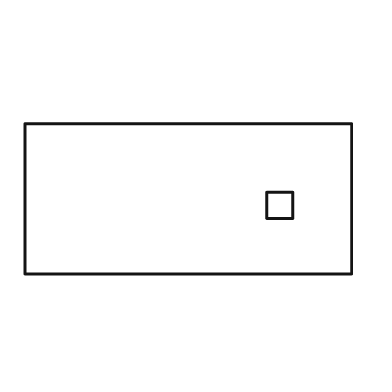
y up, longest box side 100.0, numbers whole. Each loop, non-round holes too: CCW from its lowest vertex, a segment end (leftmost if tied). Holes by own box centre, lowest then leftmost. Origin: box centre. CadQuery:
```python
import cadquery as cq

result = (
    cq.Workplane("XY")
    .moveTo(-50.0, -23.0)
    .lineTo(50.0, -23.0)
    .lineTo(50.0, 23.0)
    .lineTo(-50.0, 23.0)
    .close()
    .moveTo(24.0, -6.0)
    .lineTo(32.0, -6.0)
    .lineTo(32.0, 2.0)
    .lineTo(24.0, 2.0)
    .close()
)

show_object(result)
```